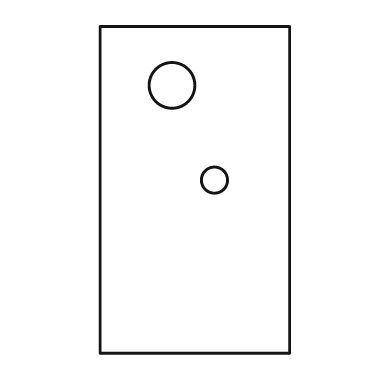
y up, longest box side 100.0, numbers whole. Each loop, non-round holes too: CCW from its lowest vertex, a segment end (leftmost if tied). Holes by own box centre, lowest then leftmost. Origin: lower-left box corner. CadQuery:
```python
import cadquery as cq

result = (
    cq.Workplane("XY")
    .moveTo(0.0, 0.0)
    .lineTo(58.0, 0.0)
    .lineTo(58.0, 100.0)
    .lineTo(0.0, 100.0)
    .close()
    .moveTo(35.0, 53.0)
    .circle(4.0)
    .moveTo(22.0, 82.0)
    .circle(7.0)
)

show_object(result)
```